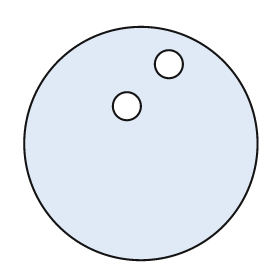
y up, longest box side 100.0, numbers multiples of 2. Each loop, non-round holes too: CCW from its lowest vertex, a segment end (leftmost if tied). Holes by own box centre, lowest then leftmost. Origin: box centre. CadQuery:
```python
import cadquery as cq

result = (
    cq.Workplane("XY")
    .moveTo(0.0, 0.0)
    .circle(50.0)
    .moveTo(-6.0, 16.0)
    .circle(6.0)
    .moveTo(12.0, 34.0)
    .circle(6.0)
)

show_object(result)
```